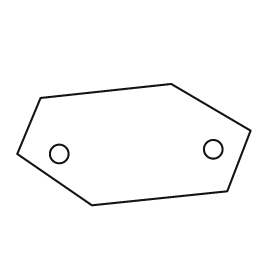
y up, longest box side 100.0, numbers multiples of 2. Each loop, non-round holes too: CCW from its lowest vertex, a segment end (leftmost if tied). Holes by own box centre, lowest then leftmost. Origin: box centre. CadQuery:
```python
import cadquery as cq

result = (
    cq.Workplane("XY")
    .moveTo(-18.0, -26.0)
    .lineTo(40.0, -20.0)
    .lineTo(50.0, 6.0)
    .lineTo(16.0, 26.0)
    .lineTo(-40.0, 20.0)
    .lineTo(-50.0, -4.0)
    .close()
    .moveTo(-32.0, -4.0)
    .circle(4.0)
    .moveTo(34.0, -2.0)
    .circle(4.0)
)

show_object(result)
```